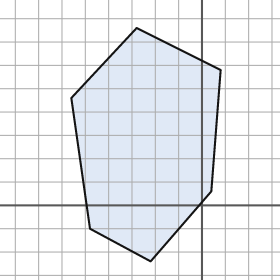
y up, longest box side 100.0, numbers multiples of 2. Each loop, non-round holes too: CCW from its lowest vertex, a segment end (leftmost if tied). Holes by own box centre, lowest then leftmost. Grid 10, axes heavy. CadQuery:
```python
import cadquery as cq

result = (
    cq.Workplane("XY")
    .moveTo(-22.0, -24.0)
    .lineTo(4.0, 6.0)
    .lineTo(8.0, 58.0)
    .lineTo(-28.0, 76.0)
    .lineTo(-56.0, 46.0)
    .lineTo(-48.0, -10.0)
    .close()
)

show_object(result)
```